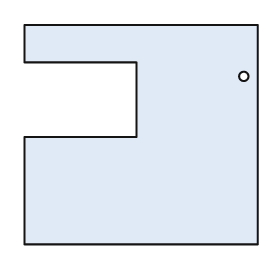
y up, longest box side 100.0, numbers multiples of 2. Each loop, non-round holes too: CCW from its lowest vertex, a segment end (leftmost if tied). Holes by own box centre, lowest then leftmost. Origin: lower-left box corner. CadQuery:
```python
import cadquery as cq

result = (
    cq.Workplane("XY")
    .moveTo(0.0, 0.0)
    .lineTo(100.0, 0.0)
    .lineTo(100.0, 94.0)
    .lineTo(0.0, 94.0)
    .lineTo(0.0, 78.0)
    .lineTo(48.0, 78.0)
    .lineTo(48.0, 46.0)
    .lineTo(0.0, 46.0)
    .close()
    .moveTo(94.0, 72.0)
    .circle(2.0)
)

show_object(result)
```